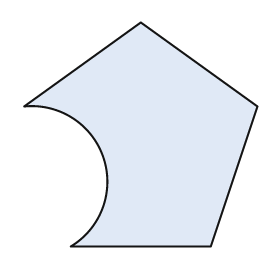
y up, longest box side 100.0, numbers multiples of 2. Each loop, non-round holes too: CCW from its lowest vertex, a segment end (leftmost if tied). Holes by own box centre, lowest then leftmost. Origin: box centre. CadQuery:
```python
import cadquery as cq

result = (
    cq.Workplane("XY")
    .moveTo(-30.0, -48.0)
    .lineTo(30.0, -48.0)
    .lineTo(50.0, 12.0)
    .lineTo(0.0, 48.0)
    .lineTo(-50.0, 12.0)
    .threePointArc((-16.0, -10.0), (-30.0, -48.0))
    .close()
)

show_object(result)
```